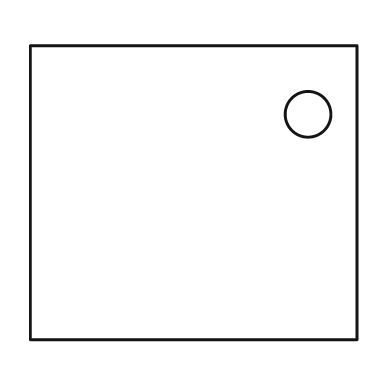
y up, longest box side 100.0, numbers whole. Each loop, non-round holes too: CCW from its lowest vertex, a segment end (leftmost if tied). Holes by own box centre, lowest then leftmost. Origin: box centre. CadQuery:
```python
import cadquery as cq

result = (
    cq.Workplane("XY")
    .moveTo(-50.0, -45.0)
    .lineTo(50.0, -45.0)
    .lineTo(50.0, 45.0)
    .lineTo(-50.0, 45.0)
    .close()
    .moveTo(35.0, 24.0)
    .circle(7.0)
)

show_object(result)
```